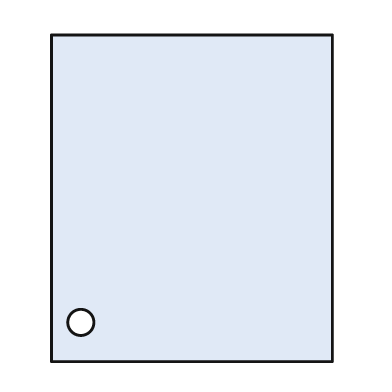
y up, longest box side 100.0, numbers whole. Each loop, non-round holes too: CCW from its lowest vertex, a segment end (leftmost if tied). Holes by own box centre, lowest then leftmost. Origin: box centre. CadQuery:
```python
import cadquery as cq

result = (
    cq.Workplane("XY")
    .moveTo(-43.0, -50.0)
    .lineTo(43.0, -50.0)
    .lineTo(43.0, 50.0)
    .lineTo(-43.0, 50.0)
    .close()
    .moveTo(-34.0, -38.0)
    .circle(4.0)
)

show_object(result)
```